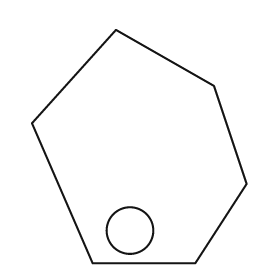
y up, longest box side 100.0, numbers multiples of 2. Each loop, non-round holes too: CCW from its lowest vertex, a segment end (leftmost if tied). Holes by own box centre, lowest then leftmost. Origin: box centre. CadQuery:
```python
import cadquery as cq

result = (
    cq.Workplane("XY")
    .moveTo(-20.0, -50.0)
    .lineTo(24.0, -50.0)
    .lineTo(46.0, -16.0)
    .lineTo(32.0, 26.0)
    .lineTo(-10.0, 50.0)
    .lineTo(-46.0, 10.0)
    .close()
    .moveTo(-4.0, -36.0)
    .circle(10.0)
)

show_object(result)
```